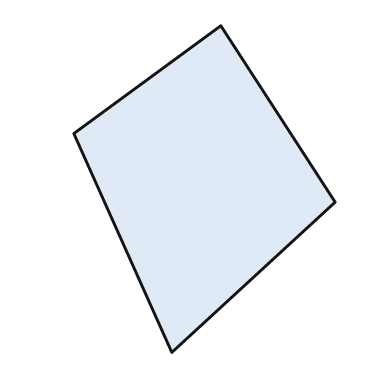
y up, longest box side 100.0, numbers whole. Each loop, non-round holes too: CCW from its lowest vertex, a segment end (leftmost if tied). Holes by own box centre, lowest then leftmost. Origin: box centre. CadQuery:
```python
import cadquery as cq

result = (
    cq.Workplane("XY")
    .moveTo(-10.0, -50.0)
    .lineTo(40.0, -4.0)
    .lineTo(5.0, 50.0)
    .lineTo(-40.0, 17.0)
    .close()
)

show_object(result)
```